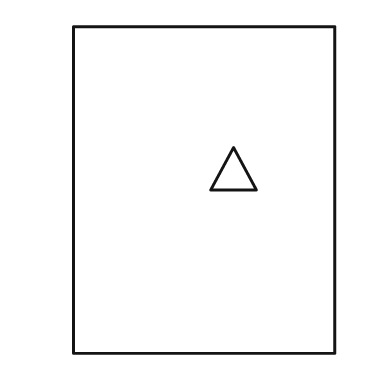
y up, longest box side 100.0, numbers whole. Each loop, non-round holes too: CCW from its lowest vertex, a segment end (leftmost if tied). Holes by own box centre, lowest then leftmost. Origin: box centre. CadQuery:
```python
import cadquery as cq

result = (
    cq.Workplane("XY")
    .moveTo(-40.0, -50.0)
    .lineTo(40.0, -50.0)
    .lineTo(40.0, 50.0)
    .lineTo(-40.0, 50.0)
    .close()
    .moveTo(2.0, 0.0)
    .lineTo(16.0, 0.0)
    .lineTo(9.0, 13.0)
    .close()
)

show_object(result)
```